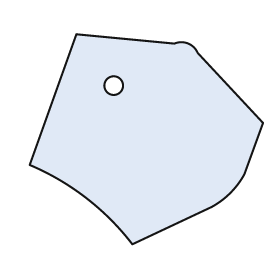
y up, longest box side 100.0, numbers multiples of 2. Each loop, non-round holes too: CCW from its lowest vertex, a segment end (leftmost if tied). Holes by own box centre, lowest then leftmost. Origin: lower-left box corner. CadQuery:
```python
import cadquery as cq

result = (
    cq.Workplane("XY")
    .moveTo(44.0, 0.0)
    .lineTo(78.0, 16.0)
    .threePointArc((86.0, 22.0), (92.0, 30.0))
    .lineTo(100.0, 52.0)
    .lineTo(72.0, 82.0)
    .threePointArc((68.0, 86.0), (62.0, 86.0))
    .lineTo(20.0, 90.0)
    .lineTo(0.0, 34.0)
    .threePointArc((24.0, 20.0), (44.0, 0.0))
    .close()
    .moveTo(36.0, 68.0)
    .circle(4.0)
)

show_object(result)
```